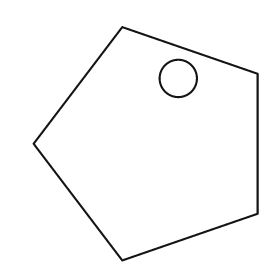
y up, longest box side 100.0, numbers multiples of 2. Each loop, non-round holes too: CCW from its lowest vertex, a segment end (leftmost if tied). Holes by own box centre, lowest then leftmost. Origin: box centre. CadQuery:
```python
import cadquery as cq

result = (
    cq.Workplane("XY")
    .moveTo(-10.0, -50.0)
    .lineTo(48.0, -30.0)
    .lineTo(48.0, 30.0)
    .lineTo(-10.0, 50.0)
    .lineTo(-48.0, 0.0)
    .close()
    .moveTo(14.0, 28.0)
    .circle(8.0)
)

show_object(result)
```